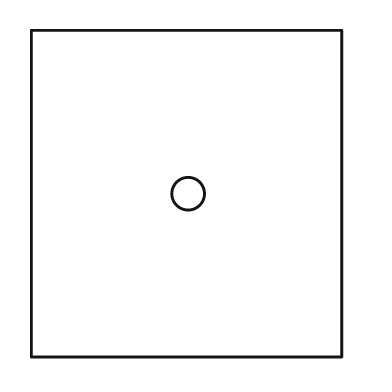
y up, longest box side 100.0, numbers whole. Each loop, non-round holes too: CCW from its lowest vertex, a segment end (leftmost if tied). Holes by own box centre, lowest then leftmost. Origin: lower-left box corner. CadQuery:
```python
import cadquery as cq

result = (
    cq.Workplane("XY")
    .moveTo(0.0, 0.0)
    .lineTo(95.0, 0.0)
    .lineTo(95.0, 100.0)
    .lineTo(0.0, 100.0)
    .close()
    .moveTo(48.0, 50.0)
    .circle(5.0)
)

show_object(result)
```